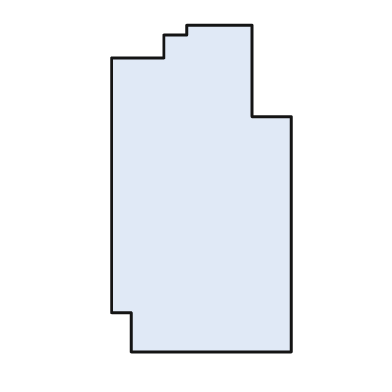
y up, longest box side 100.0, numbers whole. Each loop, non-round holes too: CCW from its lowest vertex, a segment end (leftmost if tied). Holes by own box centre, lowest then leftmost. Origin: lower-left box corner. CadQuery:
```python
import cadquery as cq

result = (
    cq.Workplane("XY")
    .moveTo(6.0, 0.0)
    .lineTo(55.0, 0.0)
    .lineTo(55.0, 72.0)
    .lineTo(43.0, 72.0)
    .lineTo(43.0, 100.0)
    .lineTo(23.0, 100.0)
    .lineTo(23.0, 97.0)
    .lineTo(16.0, 97.0)
    .lineTo(16.0, 90.0)
    .lineTo(0.0, 90.0)
    .lineTo(0.0, 12.0)
    .lineTo(6.0, 12.0)
    .close()
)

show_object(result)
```